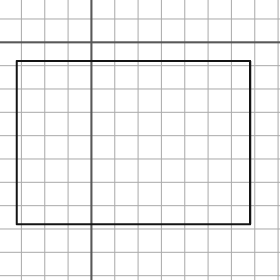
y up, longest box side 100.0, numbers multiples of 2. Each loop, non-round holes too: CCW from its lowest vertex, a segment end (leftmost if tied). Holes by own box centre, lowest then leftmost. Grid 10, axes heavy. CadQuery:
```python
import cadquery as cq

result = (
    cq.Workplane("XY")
    .moveTo(-32.0, -78.0)
    .lineTo(68.0, -78.0)
    .lineTo(68.0, -8.0)
    .lineTo(-32.0, -8.0)
    .close()
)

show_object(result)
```